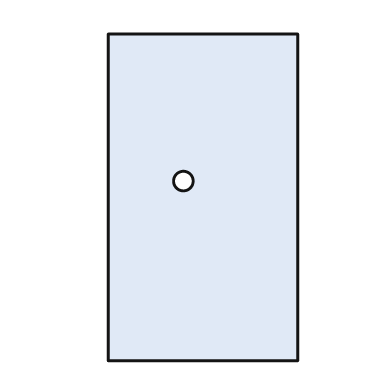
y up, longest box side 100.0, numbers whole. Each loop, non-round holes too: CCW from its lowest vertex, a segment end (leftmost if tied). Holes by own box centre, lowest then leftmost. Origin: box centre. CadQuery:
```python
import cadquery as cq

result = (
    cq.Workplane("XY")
    .moveTo(-29.0, -50.0)
    .lineTo(29.0, -50.0)
    .lineTo(29.0, 50.0)
    .lineTo(-29.0, 50.0)
    .close()
    .moveTo(-6.0, 5.0)
    .circle(3.0)
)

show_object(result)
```